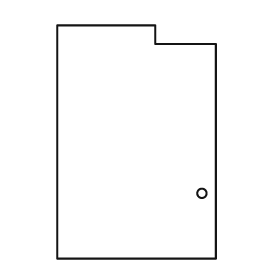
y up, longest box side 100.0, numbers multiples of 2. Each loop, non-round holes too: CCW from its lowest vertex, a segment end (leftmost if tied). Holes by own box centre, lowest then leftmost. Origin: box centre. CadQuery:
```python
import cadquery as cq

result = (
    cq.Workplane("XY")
    .moveTo(-34.0, -50.0)
    .lineTo(34.0, -50.0)
    .lineTo(34.0, 42.0)
    .lineTo(8.0, 42.0)
    .lineTo(8.0, 50.0)
    .lineTo(-34.0, 50.0)
    .close()
    .moveTo(28.0, -22.0)
    .circle(2.0)
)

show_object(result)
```